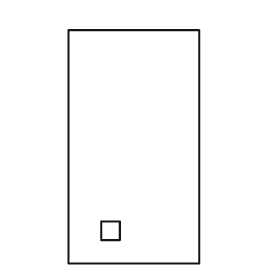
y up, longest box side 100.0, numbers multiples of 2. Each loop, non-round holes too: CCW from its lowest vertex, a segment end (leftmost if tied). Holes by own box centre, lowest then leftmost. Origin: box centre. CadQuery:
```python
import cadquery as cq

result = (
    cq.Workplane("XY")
    .moveTo(-28.0, -50.0)
    .lineTo(28.0, -50.0)
    .lineTo(28.0, 50.0)
    .lineTo(-28.0, 50.0)
    .close()
    .moveTo(-14.0, -40.0)
    .lineTo(-6.0, -40.0)
    .lineTo(-6.0, -32.0)
    .lineTo(-14.0, -32.0)
    .close()
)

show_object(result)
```